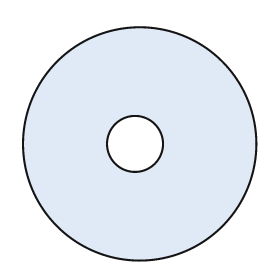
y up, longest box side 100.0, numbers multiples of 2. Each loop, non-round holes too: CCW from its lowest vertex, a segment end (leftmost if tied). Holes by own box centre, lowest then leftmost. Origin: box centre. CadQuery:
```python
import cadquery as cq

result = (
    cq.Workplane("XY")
    .moveTo(0.0, 0.0)
    .circle(50.0)
    .moveTo(-2.0, 0.0)
    .circle(12.0)
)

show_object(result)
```